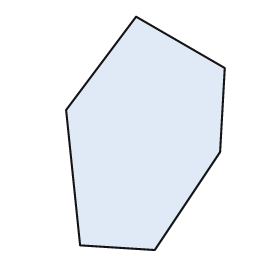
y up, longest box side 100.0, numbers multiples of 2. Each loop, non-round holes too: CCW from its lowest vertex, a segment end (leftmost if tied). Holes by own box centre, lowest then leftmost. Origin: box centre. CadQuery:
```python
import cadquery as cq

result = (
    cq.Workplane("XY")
    .moveTo(4.0, -50.0)
    .lineTo(32.0, -8.0)
    .lineTo(34.0, 28.0)
    .lineTo(-4.0, 50.0)
    .lineTo(-34.0, 10.0)
    .lineTo(-28.0, -48.0)
    .close()
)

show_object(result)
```